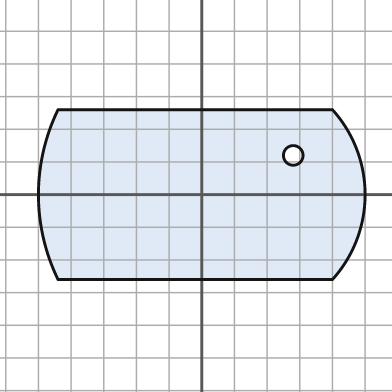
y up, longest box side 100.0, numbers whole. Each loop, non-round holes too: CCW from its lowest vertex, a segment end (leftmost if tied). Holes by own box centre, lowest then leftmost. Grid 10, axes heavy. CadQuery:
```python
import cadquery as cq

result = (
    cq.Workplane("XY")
    .moveTo(-44.0, -26.0)
    .lineTo(40.0, -26.0)
    .threePointArc((50.0, 0.0), (40.0, 26.0))
    .lineTo(-44.0, 26.0)
    .threePointArc((-50.0, 0.0), (-44.0, -26.0))
    .close()
    .moveTo(28.0, 12.0)
    .circle(3.0)
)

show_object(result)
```